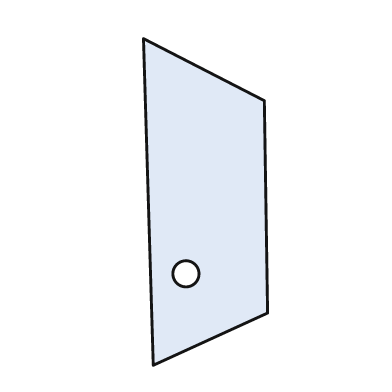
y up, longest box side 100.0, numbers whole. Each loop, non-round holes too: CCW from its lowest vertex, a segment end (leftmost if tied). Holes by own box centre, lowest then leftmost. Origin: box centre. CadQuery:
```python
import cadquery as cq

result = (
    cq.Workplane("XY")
    .moveTo(-16.0, -50.0)
    .lineTo(19.0, -34.0)
    .lineTo(18.0, 31.0)
    .lineTo(-19.0, 50.0)
    .close()
    .moveTo(-6.0, -22.0)
    .circle(4.0)
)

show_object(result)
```